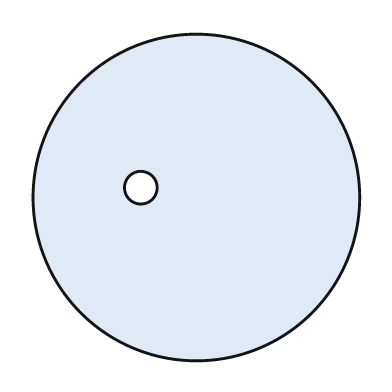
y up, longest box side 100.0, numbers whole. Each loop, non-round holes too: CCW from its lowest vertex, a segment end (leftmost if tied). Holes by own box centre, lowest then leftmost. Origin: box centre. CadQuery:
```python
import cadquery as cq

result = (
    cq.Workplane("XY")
    .moveTo(0.0, 0.0)
    .circle(50.0)
    .moveTo(-17.0, 3.0)
    .circle(5.0)
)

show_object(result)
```